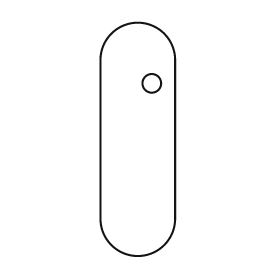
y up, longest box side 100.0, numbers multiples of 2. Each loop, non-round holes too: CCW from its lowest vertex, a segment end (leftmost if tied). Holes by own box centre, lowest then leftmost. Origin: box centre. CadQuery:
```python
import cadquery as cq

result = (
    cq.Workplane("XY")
    .moveTo(-16.0, -34.0)
    .threePointArc((0.0, -50.0), (16.0, -34.0))
    .lineTo(16.0, 34.0)
    .threePointArc((0.0, 50.0), (-16.0, 34.0))
    .close()
    .moveTo(6.0, 24.0)
    .circle(4.0)
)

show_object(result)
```